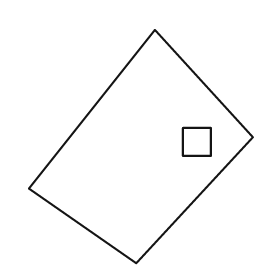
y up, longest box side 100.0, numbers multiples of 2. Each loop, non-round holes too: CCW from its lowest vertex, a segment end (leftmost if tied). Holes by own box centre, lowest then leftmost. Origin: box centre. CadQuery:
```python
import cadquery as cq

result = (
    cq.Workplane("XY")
    .moveTo(-2.0, -50.0)
    .lineTo(48.0, 4.0)
    .lineTo(6.0, 50.0)
    .lineTo(-48.0, -18.0)
    .close()
    .moveTo(18.0, -4.0)
    .lineTo(30.0, -4.0)
    .lineTo(30.0, 8.0)
    .lineTo(18.0, 8.0)
    .close()
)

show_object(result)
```